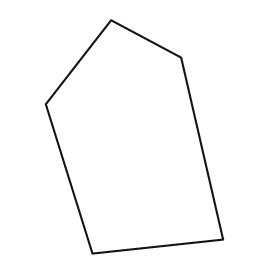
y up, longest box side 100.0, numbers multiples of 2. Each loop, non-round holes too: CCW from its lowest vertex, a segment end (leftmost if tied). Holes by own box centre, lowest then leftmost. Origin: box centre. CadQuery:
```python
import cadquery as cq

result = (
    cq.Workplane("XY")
    .moveTo(-18.0, -50.0)
    .lineTo(38.0, -44.0)
    .lineTo(20.0, 34.0)
    .lineTo(-10.0, 50.0)
    .lineTo(-38.0, 14.0)
    .close()
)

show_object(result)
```